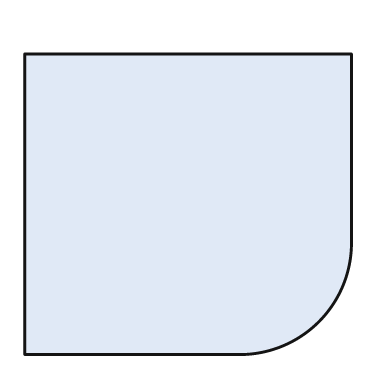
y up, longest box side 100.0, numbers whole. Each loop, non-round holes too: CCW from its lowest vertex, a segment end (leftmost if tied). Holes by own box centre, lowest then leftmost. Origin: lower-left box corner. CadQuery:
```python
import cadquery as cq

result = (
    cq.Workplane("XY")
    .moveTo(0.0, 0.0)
    .lineTo(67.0, 0.0)
    .threePointArc((90.0, 10.0), (100.0, 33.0))
    .lineTo(100.0, 92.0)
    .lineTo(0.0, 92.0)
    .close()
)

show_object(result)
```